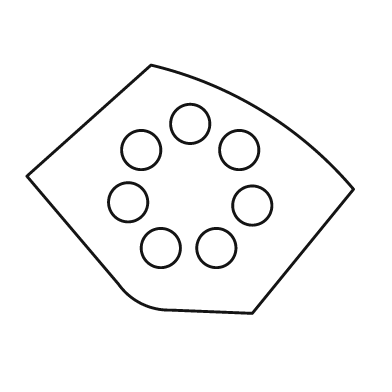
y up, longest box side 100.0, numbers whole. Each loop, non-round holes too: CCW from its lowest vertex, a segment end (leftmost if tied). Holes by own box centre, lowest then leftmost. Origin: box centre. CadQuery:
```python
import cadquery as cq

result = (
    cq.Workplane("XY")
    .moveTo(19.0, -38.0)
    .lineTo(50.0, 0.0)
    .threePointArc((22.0, 24.0), (-12.0, 38.0))
    .lineTo(-50.0, 4.0)
    .lineTo(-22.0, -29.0)
    .threePointArc((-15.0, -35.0), (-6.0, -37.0))
    .close()
    .moveTo(-9.0, -18.0)
    .circle(6.0)
    .moveTo(8.0, -18.0)
    .circle(6.0)
    .moveTo(19.0, -5.0)
    .circle(6.0)
    .moveTo(-19.0, -4.0)
    .circle(6.0)
    .moveTo(-15.0, 12.0)
    .circle(6.0)
    .moveTo(15.0, 12.0)
    .circle(6.0)
    .moveTo(0.0, 20.0)
    .circle(6.0)
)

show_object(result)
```